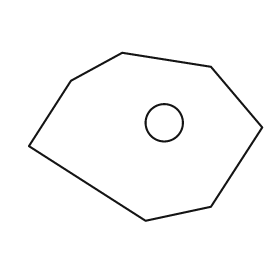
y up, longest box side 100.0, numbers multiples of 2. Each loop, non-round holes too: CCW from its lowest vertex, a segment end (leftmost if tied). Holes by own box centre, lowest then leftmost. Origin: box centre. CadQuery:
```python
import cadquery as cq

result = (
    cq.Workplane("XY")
    .moveTo(0.0, -36.0)
    .lineTo(28.0, -30.0)
    .lineTo(50.0, 4.0)
    .lineTo(28.0, 30.0)
    .lineTo(-10.0, 36.0)
    .lineTo(-32.0, 24.0)
    .lineTo(-50.0, -4.0)
    .close()
    .moveTo(8.0, 6.0)
    .circle(8.0)
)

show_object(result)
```